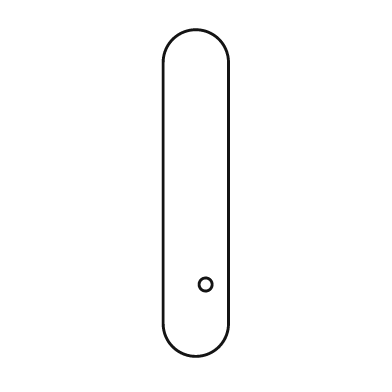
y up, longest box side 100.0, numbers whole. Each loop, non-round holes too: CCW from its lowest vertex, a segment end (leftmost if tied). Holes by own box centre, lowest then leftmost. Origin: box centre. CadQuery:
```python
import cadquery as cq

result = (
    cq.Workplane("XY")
    .moveTo(-10.0, -40.0)
    .threePointArc((0.0, -50.0), (10.0, -40.0))
    .lineTo(10.0, 40.0)
    .threePointArc((0.0, 50.0), (-10.0, 40.0))
    .close()
    .moveTo(3.0, -28.0)
    .circle(2.0)
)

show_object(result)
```